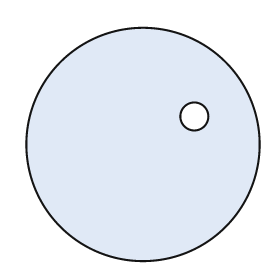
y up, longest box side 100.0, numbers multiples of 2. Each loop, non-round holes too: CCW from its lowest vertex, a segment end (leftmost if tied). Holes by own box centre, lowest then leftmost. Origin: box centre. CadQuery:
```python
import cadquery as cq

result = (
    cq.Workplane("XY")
    .moveTo(0.0, 0.0)
    .circle(50.0)
    .moveTo(22.0, 12.0)
    .circle(6.0)
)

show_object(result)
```